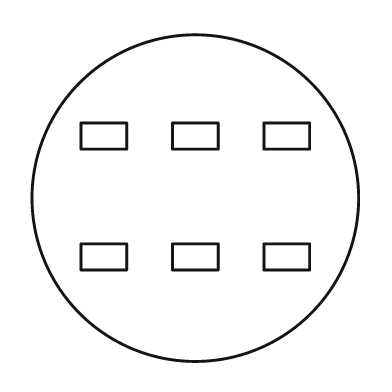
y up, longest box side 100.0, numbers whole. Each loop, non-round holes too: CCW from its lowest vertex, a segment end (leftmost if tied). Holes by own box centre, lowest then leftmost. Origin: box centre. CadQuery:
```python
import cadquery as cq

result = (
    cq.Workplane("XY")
    .moveTo(0.0, 0.0)
    .circle(50.0)
    .moveTo(-35.0, -22.0)
    .lineTo(-21.0, -22.0)
    .lineTo(-21.0, -14.0)
    .lineTo(-35.0, -14.0)
    .close()
    .moveTo(-7.0, -22.0)
    .lineTo(7.0, -22.0)
    .lineTo(7.0, -14.0)
    .lineTo(-7.0, -14.0)
    .close()
    .moveTo(21.0, -22.0)
    .lineTo(35.0, -22.0)
    .lineTo(35.0, -14.0)
    .lineTo(21.0, -14.0)
    .close()
    .moveTo(-35.0, 15.0)
    .lineTo(-21.0, 15.0)
    .lineTo(-21.0, 23.0)
    .lineTo(-35.0, 23.0)
    .close()
    .moveTo(-7.0, 15.0)
    .lineTo(7.0, 15.0)
    .lineTo(7.0, 23.0)
    .lineTo(-7.0, 23.0)
    .close()
    .moveTo(21.0, 15.0)
    .lineTo(35.0, 15.0)
    .lineTo(35.0, 23.0)
    .lineTo(21.0, 23.0)
    .close()
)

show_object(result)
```